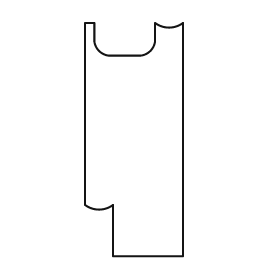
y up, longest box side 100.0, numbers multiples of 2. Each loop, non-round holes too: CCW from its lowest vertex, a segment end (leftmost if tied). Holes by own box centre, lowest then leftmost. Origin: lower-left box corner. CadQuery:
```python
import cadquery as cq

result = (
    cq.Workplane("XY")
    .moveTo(12.0, 0.0)
    .lineTo(42.0, 0.0)
    .lineTo(42.0, 100.0)
    .threePointArc((36.0, 98.0), (30.0, 100.0))
    .lineTo(30.0, 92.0)
    .threePointArc((28.0, 88.0), (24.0, 86.0))
    .lineTo(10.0, 86.0)
    .threePointArc((6.0, 88.0), (4.0, 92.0))
    .lineTo(4.0, 100.0)
    .lineTo(0.0, 100.0)
    .lineTo(0.0, 22.0)
    .threePointArc((6.0, 20.0), (12.0, 22.0))
    .close()
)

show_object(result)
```